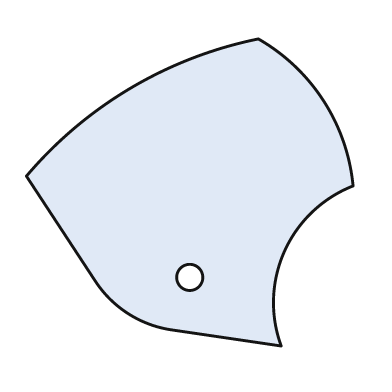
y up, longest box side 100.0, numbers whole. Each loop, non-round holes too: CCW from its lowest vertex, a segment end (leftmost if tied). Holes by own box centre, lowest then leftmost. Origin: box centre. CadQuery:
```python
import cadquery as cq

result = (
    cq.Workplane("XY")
    .moveTo(28.0, -47.0)
    .threePointArc((29.0, -18.0), (50.0, 2.0))
    .threePointArc((41.0, 28.0), (21.0, 47.0))
    .threePointArc((-18.0, 32.0), (-50.0, 5.0))
    .lineTo(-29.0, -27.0)
    .threePointArc((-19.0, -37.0), (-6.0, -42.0))
    .close()
    .moveTo(0.0, -26.0)
    .circle(4.0)
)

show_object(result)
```